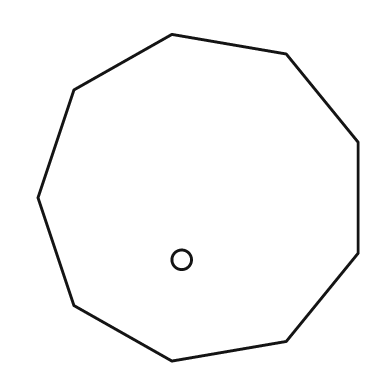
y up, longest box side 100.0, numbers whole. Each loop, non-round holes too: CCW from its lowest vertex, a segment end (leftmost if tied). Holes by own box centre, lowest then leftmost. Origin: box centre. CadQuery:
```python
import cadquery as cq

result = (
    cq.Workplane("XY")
    .moveTo(-8.0, -50.0)
    .lineTo(27.0, -44.0)
    .lineTo(49.0, -17.0)
    .lineTo(49.0, 17.0)
    .lineTo(27.0, 44.0)
    .lineTo(-8.0, 50.0)
    .lineTo(-38.0, 33.0)
    .lineTo(-49.0, 0.0)
    .lineTo(-38.0, -33.0)
    .close()
    .moveTo(-5.0, -19.0)
    .circle(3.0)
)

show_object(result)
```